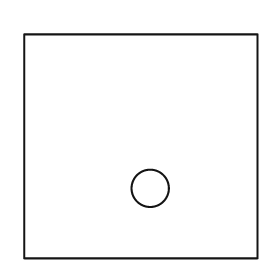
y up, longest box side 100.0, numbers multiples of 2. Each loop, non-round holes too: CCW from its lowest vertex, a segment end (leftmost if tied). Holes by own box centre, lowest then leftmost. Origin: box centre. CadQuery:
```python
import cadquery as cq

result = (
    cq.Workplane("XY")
    .moveTo(-50.0, -48.0)
    .lineTo(50.0, -48.0)
    .lineTo(50.0, 48.0)
    .lineTo(-50.0, 48.0)
    .close()
    .moveTo(4.0, -18.0)
    .circle(8.0)
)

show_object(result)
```